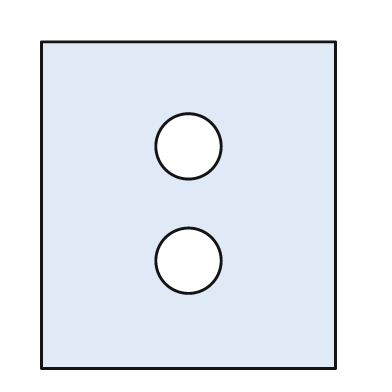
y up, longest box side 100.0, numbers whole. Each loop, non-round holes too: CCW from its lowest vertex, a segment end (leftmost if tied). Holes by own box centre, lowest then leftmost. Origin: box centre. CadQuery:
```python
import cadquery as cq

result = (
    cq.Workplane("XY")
    .moveTo(-45.0, -50.0)
    .lineTo(45.0, -50.0)
    .lineTo(45.0, 50.0)
    .lineTo(-45.0, 50.0)
    .close()
    .moveTo(0.0, -17.0)
    .circle(10.0)
    .moveTo(0.0, 18.0)
    .circle(10.0)
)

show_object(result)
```